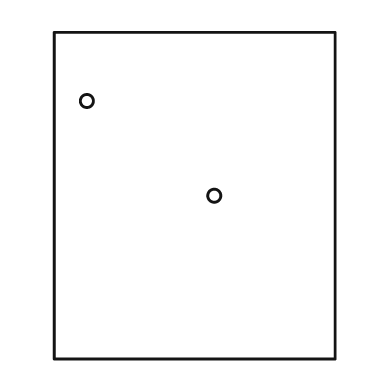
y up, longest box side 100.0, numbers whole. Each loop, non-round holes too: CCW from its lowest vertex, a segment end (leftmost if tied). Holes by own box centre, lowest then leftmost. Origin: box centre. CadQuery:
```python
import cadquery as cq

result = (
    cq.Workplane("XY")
    .moveTo(-43.0, -50.0)
    .lineTo(43.0, -50.0)
    .lineTo(43.0, 50.0)
    .lineTo(-43.0, 50.0)
    .close()
    .moveTo(6.0, 0.0)
    .circle(2.0)
    .moveTo(-33.0, 29.0)
    .circle(2.0)
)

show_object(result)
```